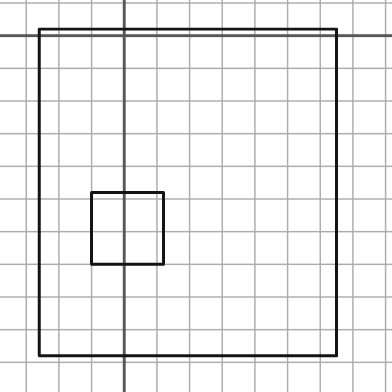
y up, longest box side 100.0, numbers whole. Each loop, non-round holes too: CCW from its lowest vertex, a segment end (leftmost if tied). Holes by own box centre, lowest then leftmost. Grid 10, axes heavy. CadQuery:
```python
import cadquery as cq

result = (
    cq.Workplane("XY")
    .moveTo(-26.0, -98.0)
    .lineTo(65.0, -98.0)
    .lineTo(65.0, 2.0)
    .lineTo(-26.0, 2.0)
    .close()
    .moveTo(-10.0, -70.0)
    .lineTo(12.0, -70.0)
    .lineTo(12.0, -48.0)
    .lineTo(-10.0, -48.0)
    .close()
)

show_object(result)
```